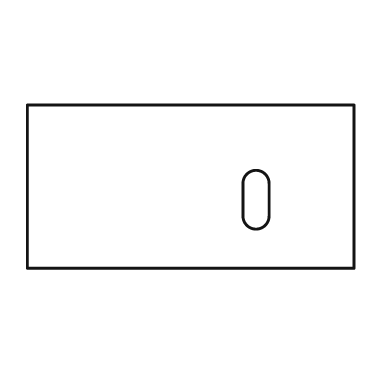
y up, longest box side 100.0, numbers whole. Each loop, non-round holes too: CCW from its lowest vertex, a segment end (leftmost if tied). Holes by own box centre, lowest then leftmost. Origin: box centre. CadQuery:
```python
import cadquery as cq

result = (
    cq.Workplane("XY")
    .moveTo(-50.0, -25.0)
    .lineTo(50.0, -25.0)
    .lineTo(50.0, 25.0)
    .lineTo(-50.0, 25.0)
    .close()
    .moveTo(16.0, -9.0)
    .threePointArc((20.0, -13.0), (24.0, -9.0))
    .lineTo(24.0, 1.0)
    .threePointArc((20.0, 5.0), (16.0, 1.0))
    .close()
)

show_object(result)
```